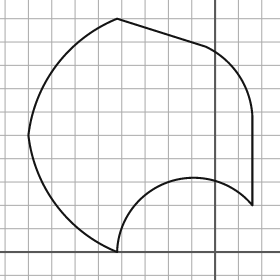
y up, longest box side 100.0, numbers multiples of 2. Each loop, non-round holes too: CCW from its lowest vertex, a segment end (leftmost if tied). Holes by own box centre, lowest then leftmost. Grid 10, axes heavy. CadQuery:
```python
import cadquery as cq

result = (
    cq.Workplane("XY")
    .moveTo(-42.0, 0.0)
    .threePointArc((-20.0, 30.0), (16.0, 20.0))
    .lineTo(16.0, 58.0)
    .threePointArc((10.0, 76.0), (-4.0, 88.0))
    .lineTo(-42.0, 100.0)
    .threePointArc((-68.0, 80.0), (-80.0, 50.0))
    .threePointArc((-68.0, 20.0), (-42.0, 0.0))
    .close()
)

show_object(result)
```